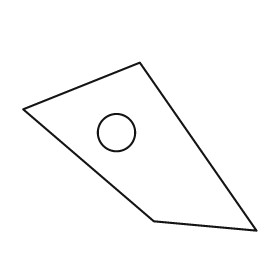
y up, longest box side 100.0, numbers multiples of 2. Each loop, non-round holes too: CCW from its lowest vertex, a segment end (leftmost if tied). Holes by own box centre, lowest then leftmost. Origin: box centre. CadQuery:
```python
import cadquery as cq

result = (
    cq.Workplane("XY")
    .moveTo(50.0, -36.0)
    .lineTo(0.0, 36.0)
    .lineTo(-50.0, 16.0)
    .lineTo(6.0, -32.0)
    .close()
    .moveTo(-10.0, 6.0)
    .circle(8.0)
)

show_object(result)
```